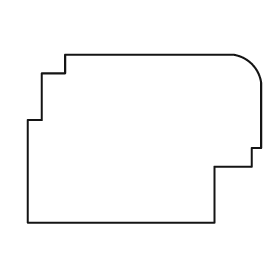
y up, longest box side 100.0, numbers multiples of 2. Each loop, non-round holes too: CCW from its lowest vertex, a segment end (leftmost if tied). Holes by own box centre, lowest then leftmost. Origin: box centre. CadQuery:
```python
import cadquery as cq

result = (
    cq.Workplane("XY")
    .moveTo(-50.0, -36.0)
    .lineTo(30.0, -36.0)
    .lineTo(30.0, -12.0)
    .lineTo(46.0, -12.0)
    .lineTo(46.0, -4.0)
    .lineTo(50.0, -4.0)
    .lineTo(50.0, 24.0)
    .threePointArc((46.0, 32.0), (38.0, 36.0))
    .lineTo(-34.0, 36.0)
    .lineTo(-34.0, 28.0)
    .lineTo(-44.0, 28.0)
    .lineTo(-44.0, 8.0)
    .lineTo(-50.0, 8.0)
    .close()
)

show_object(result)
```